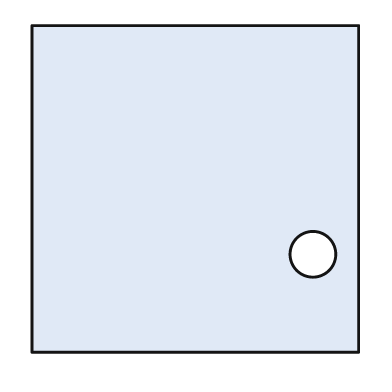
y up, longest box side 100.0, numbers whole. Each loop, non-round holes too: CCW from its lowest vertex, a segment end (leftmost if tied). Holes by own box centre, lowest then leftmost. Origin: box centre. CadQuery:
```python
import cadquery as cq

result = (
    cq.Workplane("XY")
    .moveTo(-50.0, -50.0)
    .lineTo(50.0, -50.0)
    .lineTo(50.0, 50.0)
    .lineTo(-50.0, 50.0)
    .close()
    .moveTo(36.0, -20.0)
    .circle(7.0)
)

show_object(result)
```